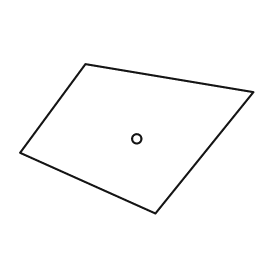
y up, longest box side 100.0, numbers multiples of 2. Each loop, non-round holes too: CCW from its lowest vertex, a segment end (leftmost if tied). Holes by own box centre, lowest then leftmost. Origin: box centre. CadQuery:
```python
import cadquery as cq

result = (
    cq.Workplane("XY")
    .moveTo(8.0, -32.0)
    .lineTo(50.0, 20.0)
    .lineTo(-22.0, 32.0)
    .lineTo(-50.0, -6.0)
    .close()
    .moveTo(0.0, 0.0)
    .circle(2.0)
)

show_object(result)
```